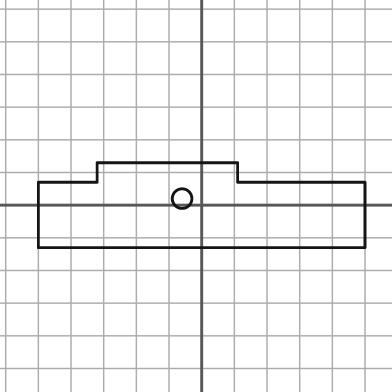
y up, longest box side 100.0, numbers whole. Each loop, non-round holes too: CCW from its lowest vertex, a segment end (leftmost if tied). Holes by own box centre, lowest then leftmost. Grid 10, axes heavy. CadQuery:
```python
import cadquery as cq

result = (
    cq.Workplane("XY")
    .moveTo(-50.0, -13.0)
    .lineTo(50.0, -13.0)
    .lineTo(50.0, 7.0)
    .lineTo(11.0, 7.0)
    .lineTo(11.0, 13.0)
    .lineTo(-32.0, 13.0)
    .lineTo(-32.0, 7.0)
    .lineTo(-50.0, 7.0)
    .close()
    .moveTo(-6.0, 2.0)
    .circle(3.0)
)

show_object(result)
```